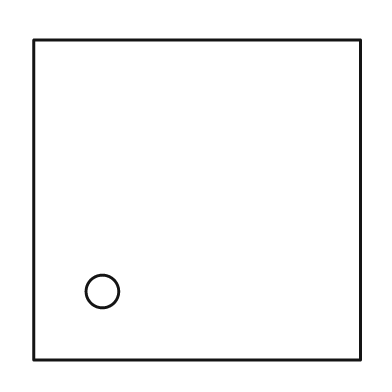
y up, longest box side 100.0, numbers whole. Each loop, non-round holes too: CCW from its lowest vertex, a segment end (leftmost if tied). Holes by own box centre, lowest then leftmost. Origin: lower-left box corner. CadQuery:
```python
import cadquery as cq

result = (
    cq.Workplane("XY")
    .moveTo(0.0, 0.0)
    .lineTo(100.0, 0.0)
    .lineTo(100.0, 98.0)
    .lineTo(0.0, 98.0)
    .close()
    .moveTo(21.0, 21.0)
    .circle(5.0)
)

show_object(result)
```